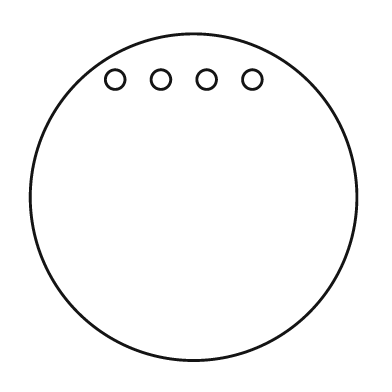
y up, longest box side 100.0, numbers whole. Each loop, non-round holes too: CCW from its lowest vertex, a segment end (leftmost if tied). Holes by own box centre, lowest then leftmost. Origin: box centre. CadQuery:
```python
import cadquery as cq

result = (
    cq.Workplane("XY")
    .moveTo(0.0, 0.0)
    .circle(50.0)
    .moveTo(-24.0, 36.0)
    .circle(3.0)
    .moveTo(-10.0, 36.0)
    .circle(3.0)
    .moveTo(4.0, 36.0)
    .circle(3.0)
    .moveTo(18.0, 36.0)
    .circle(3.0)
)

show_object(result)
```